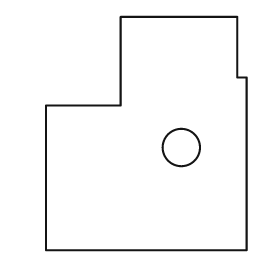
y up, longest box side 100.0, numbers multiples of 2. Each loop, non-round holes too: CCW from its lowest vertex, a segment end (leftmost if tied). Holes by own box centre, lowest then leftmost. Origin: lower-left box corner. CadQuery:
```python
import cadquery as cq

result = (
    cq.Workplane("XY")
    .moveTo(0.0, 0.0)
    .lineTo(86.0, 0.0)
    .lineTo(86.0, 74.0)
    .lineTo(82.0, 74.0)
    .lineTo(82.0, 100.0)
    .lineTo(32.0, 100.0)
    .lineTo(32.0, 62.0)
    .lineTo(0.0, 62.0)
    .close()
    .moveTo(58.0, 44.0)
    .circle(8.0)
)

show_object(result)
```